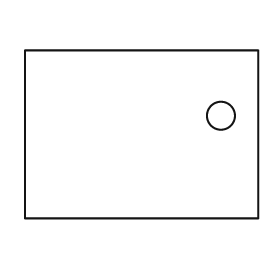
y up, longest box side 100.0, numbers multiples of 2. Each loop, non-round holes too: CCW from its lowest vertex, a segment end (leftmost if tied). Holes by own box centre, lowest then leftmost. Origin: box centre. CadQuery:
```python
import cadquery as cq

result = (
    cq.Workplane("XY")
    .moveTo(-50.0, -36.0)
    .lineTo(50.0, -36.0)
    .lineTo(50.0, 36.0)
    .lineTo(-50.0, 36.0)
    .close()
    .moveTo(34.0, 8.0)
    .circle(6.0)
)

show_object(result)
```